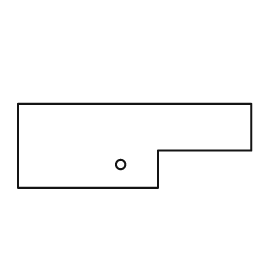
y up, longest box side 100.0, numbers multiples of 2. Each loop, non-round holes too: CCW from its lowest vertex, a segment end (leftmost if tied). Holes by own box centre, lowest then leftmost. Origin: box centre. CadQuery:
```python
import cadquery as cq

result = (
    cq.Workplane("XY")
    .moveTo(-50.0, -18.0)
    .lineTo(10.0, -18.0)
    .lineTo(10.0, -2.0)
    .lineTo(50.0, -2.0)
    .lineTo(50.0, 18.0)
    .lineTo(-50.0, 18.0)
    .close()
    .moveTo(-6.0, -8.0)
    .circle(2.0)
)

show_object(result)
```